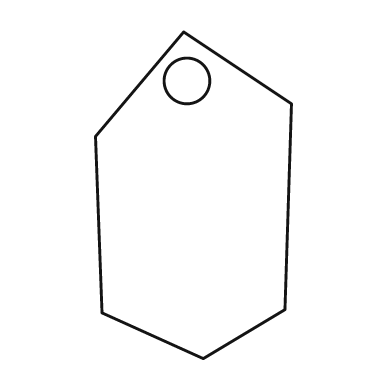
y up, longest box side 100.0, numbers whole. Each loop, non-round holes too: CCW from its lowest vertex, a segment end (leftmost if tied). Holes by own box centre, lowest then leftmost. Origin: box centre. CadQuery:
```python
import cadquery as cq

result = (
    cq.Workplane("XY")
    .moveTo(3.0, -50.0)
    .lineTo(28.0, -35.0)
    .lineTo(30.0, 28.0)
    .lineTo(-3.0, 50.0)
    .lineTo(-30.0, 18.0)
    .lineTo(-28.0, -36.0)
    .close()
    .moveTo(-2.0, 35.0)
    .circle(7.0)
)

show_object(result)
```